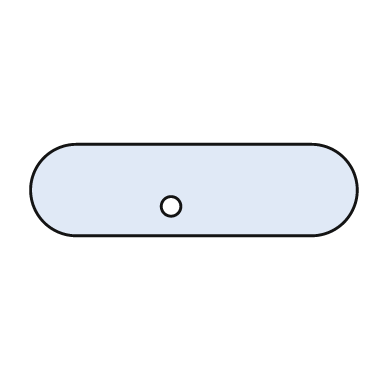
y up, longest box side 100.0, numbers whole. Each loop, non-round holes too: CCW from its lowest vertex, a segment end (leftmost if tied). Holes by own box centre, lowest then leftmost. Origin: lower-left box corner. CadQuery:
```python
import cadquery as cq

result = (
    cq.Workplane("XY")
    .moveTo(14.0, 0.0)
    .lineTo(86.0, 0.0)
    .threePointArc((100.0, 14.0), (86.0, 28.0))
    .lineTo(14.0, 28.0)
    .threePointArc((0.0, 14.0), (14.0, 0.0))
    .close()
    .moveTo(43.0, 9.0)
    .circle(3.0)
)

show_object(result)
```